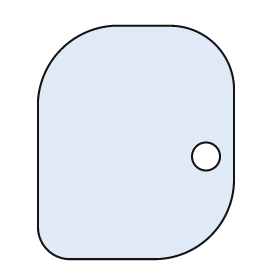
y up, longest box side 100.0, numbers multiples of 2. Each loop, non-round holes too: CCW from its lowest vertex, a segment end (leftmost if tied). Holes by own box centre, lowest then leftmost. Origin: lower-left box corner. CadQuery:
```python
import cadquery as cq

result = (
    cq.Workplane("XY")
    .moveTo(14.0, 0.0)
    .lineTo(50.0, 0.0)
    .threePointArc((74.0, 10.0), (84.0, 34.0))
    .lineTo(84.0, 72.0)
    .threePointArc((76.0, 92.0), (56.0, 100.0))
    .lineTo(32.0, 100.0)
    .threePointArc((10.0, 90.0), (0.0, 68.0))
    .lineTo(0.0, 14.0)
    .threePointArc((4.0, 4.0), (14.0, 0.0))
    .close()
    .moveTo(72.0, 44.0)
    .circle(6.0)
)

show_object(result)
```